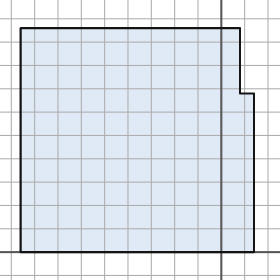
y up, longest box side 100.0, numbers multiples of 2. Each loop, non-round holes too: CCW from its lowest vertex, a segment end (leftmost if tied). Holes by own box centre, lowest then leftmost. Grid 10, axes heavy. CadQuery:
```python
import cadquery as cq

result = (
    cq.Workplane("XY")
    .moveTo(-86.0, 0.0)
    .lineTo(14.0, 0.0)
    .lineTo(14.0, 68.0)
    .lineTo(8.0, 68.0)
    .lineTo(8.0, 96.0)
    .lineTo(-86.0, 96.0)
    .close()
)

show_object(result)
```